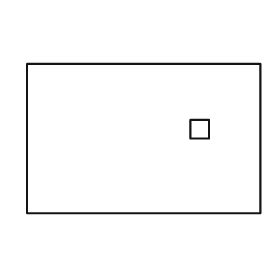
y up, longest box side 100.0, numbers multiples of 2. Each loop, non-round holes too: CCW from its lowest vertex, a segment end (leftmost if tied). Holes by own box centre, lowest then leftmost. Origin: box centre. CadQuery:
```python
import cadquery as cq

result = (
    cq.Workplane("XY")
    .moveTo(-50.0, -32.0)
    .lineTo(50.0, -32.0)
    .lineTo(50.0, 32.0)
    .lineTo(-50.0, 32.0)
    .close()
    .moveTo(20.0, 0.0)
    .lineTo(28.0, 0.0)
    .lineTo(28.0, 8.0)
    .lineTo(20.0, 8.0)
    .close()
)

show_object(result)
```